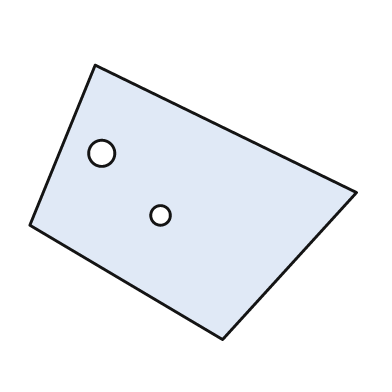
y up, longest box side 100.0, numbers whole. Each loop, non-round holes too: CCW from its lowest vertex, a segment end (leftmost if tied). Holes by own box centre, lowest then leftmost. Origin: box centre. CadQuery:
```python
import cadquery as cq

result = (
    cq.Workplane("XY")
    .moveTo(9.0, -42.0)
    .lineTo(50.0, 3.0)
    .lineTo(-30.0, 42.0)
    .lineTo(-50.0, -7.0)
    .close()
    .moveTo(-10.0, -4.0)
    .circle(3.0)
    .moveTo(-28.0, 15.0)
    .circle(4.0)
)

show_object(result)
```